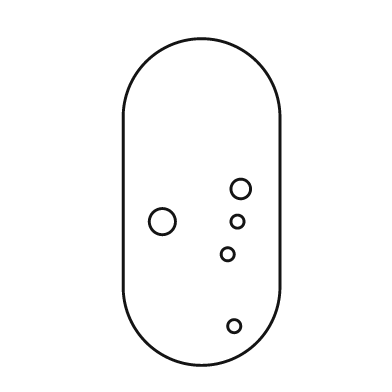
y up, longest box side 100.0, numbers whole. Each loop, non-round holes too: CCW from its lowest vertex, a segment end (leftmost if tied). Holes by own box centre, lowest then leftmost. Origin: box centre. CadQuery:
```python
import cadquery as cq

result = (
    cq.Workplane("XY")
    .moveTo(-24.0, -26.0)
    .threePointArc((0.0, -50.0), (24.0, -26.0))
    .lineTo(24.0, 26.0)
    .threePointArc((0.0, 50.0), (-24.0, 26.0))
    .close()
    .moveTo(10.0, -38.0)
    .circle(2.0)
    .moveTo(8.0, -16.0)
    .circle(2.0)
    .moveTo(-12.0, -6.0)
    .circle(4.0)
    .moveTo(11.0, -6.0)
    .circle(2.0)
    .moveTo(12.0, 4.0)
    .circle(3.0)
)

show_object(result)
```